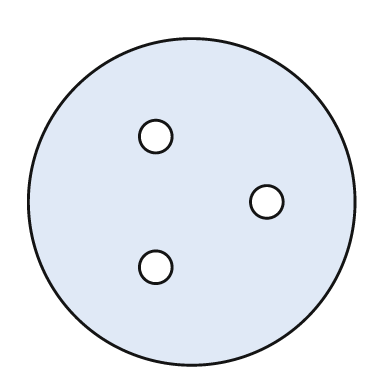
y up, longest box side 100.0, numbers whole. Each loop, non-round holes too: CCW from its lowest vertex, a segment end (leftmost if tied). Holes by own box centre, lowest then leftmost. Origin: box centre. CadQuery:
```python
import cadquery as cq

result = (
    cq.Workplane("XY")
    .moveTo(0.0, 0.0)
    .circle(50.0)
    .moveTo(-11.0, -20.0)
    .circle(5.0)
    .moveTo(23.0, 0.0)
    .circle(5.0)
    .moveTo(-11.0, 20.0)
    .circle(5.0)
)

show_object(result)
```